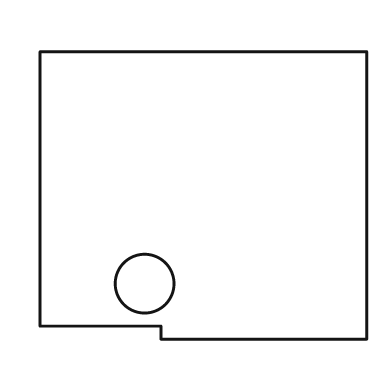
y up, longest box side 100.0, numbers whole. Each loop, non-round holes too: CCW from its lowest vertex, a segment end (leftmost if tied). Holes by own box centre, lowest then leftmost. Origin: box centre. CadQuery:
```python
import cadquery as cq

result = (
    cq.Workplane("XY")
    .moveTo(-13.0, -44.0)
    .lineTo(50.0, -44.0)
    .lineTo(50.0, 44.0)
    .lineTo(-50.0, 44.0)
    .lineTo(-50.0, -40.0)
    .lineTo(-13.0, -40.0)
    .close()
    .moveTo(-18.0, -27.0)
    .circle(9.0)
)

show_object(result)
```